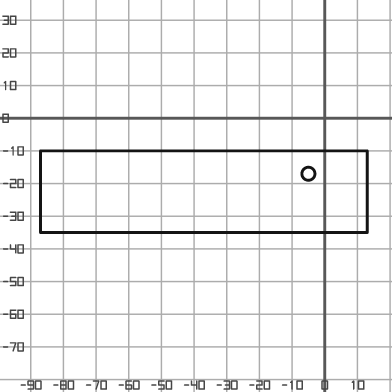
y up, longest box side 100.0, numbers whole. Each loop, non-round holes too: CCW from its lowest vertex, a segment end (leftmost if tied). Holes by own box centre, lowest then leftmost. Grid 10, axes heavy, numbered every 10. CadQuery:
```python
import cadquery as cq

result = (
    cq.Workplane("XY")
    .moveTo(-87.0, -35.0)
    .lineTo(13.0, -35.0)
    .lineTo(13.0, -10.0)
    .lineTo(-87.0, -10.0)
    .close()
    .moveTo(-5.0, -17.0)
    .circle(2.0)
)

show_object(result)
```